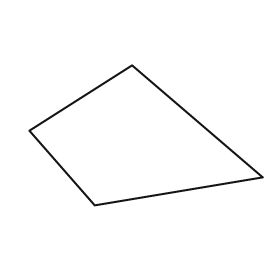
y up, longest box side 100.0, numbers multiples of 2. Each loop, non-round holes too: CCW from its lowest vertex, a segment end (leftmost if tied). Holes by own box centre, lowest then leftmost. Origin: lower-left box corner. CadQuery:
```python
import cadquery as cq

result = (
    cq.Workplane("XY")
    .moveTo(28.0, 0.0)
    .lineTo(100.0, 12.0)
    .lineTo(44.0, 60.0)
    .lineTo(0.0, 32.0)
    .close()
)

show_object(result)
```